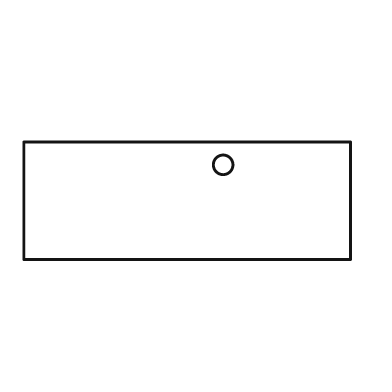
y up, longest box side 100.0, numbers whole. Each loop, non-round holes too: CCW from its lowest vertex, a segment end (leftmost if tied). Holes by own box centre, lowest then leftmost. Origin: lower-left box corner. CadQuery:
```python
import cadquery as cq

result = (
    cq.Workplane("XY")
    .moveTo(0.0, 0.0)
    .lineTo(100.0, 0.0)
    .lineTo(100.0, 36.0)
    .lineTo(0.0, 36.0)
    .close()
    .moveTo(61.0, 29.0)
    .circle(3.0)
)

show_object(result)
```